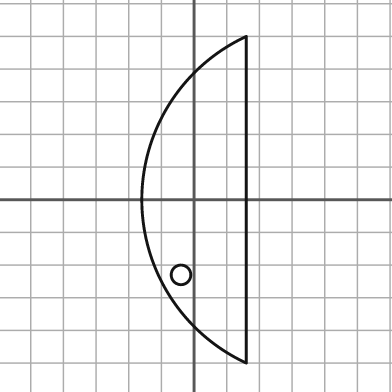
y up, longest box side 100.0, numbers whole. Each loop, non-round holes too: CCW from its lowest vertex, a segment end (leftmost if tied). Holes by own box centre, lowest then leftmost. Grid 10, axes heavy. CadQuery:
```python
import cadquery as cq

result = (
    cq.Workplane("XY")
    .moveTo(16.0, -50.0)
    .lineTo(16.0, 50.0)
    .threePointArc((-16.0, 0.0), (16.0, -50.0))
    .close()
    .moveTo(-4.0, -23.0)
    .circle(3.0)
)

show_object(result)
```